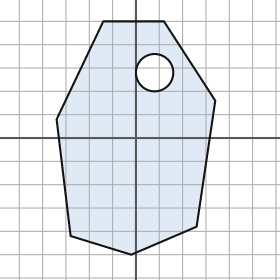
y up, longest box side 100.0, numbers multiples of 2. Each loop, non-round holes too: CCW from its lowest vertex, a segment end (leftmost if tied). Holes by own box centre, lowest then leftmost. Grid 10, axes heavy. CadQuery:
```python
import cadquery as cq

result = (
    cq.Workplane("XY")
    .moveTo(-2.0, -50.0)
    .lineTo(26.0, -38.0)
    .lineTo(34.0, 16.0)
    .lineTo(12.0, 50.0)
    .lineTo(-14.0, 50.0)
    .lineTo(-34.0, 8.0)
    .lineTo(-28.0, -42.0)
    .close()
    .moveTo(8.0, 28.0)
    .circle(8.0)
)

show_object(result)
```